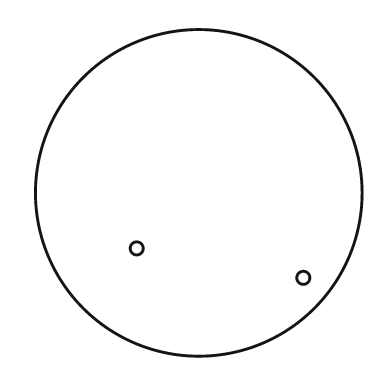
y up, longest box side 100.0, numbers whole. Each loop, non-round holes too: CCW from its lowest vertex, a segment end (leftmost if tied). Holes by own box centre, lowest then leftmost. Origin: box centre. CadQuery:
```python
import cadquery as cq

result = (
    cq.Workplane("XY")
    .moveTo(0.0, 0.0)
    .circle(50.0)
    .moveTo(32.0, -26.0)
    .circle(2.0)
    .moveTo(-19.0, -17.0)
    .circle(2.0)
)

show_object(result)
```